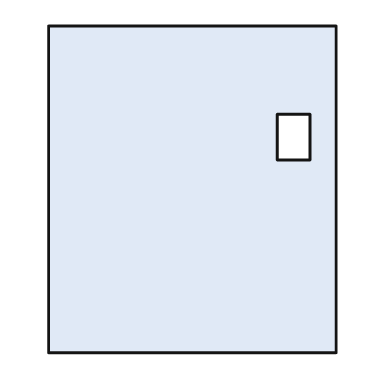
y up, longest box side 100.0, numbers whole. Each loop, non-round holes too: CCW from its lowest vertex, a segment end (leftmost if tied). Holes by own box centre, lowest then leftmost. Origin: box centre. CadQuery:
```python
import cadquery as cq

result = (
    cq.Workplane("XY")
    .moveTo(-44.0, -50.0)
    .lineTo(44.0, -50.0)
    .lineTo(44.0, 50.0)
    .lineTo(-44.0, 50.0)
    .close()
    .moveTo(26.0, 9.0)
    .lineTo(36.0, 9.0)
    .lineTo(36.0, 23.0)
    .lineTo(26.0, 23.0)
    .close()
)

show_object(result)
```